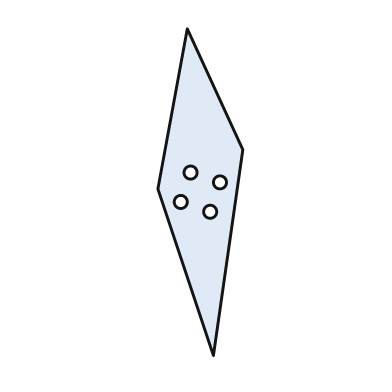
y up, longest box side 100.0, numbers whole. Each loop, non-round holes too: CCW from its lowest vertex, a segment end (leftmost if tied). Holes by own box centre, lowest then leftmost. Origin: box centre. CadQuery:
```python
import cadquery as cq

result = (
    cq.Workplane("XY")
    .moveTo(4.0, -50.0)
    .lineTo(13.0, 13.0)
    .lineTo(-4.0, 50.0)
    .lineTo(-13.0, 1.0)
    .close()
    .moveTo(3.0, -6.0)
    .circle(2.0)
    .moveTo(-6.0, -3.0)
    .circle(2.0)
    .moveTo(6.0, 3.0)
    .circle(2.0)
    .moveTo(-3.0, 6.0)
    .circle(2.0)
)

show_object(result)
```